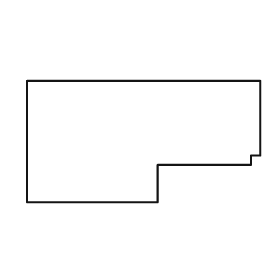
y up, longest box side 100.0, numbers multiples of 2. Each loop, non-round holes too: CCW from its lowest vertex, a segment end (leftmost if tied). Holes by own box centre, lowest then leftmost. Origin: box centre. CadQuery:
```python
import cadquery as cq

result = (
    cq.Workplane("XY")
    .moveTo(-50.0, -26.0)
    .lineTo(6.0, -26.0)
    .lineTo(6.0, -10.0)
    .lineTo(46.0, -10.0)
    .lineTo(46.0, -6.0)
    .lineTo(50.0, -6.0)
    .lineTo(50.0, 26.0)
    .lineTo(-50.0, 26.0)
    .close()
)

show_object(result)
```